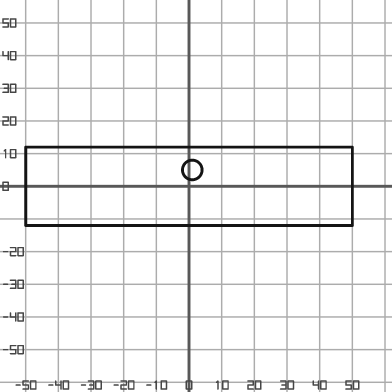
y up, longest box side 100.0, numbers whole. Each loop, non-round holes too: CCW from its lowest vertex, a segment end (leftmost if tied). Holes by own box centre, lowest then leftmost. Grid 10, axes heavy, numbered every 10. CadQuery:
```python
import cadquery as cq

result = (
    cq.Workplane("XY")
    .moveTo(-50.0, -12.0)
    .lineTo(50.0, -12.0)
    .lineTo(50.0, 12.0)
    .lineTo(-50.0, 12.0)
    .close()
    .moveTo(1.0, 5.0)
    .circle(3.0)
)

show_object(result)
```